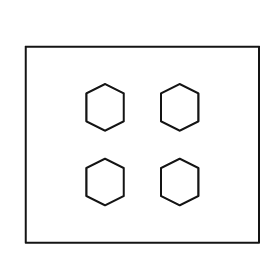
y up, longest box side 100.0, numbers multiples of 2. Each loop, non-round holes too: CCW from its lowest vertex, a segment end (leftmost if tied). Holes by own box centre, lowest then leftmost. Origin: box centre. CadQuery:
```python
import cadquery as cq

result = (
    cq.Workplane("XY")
    .moveTo(-50.0, -42.0)
    .lineTo(50.0, -42.0)
    .lineTo(50.0, 42.0)
    .lineTo(-50.0, 42.0)
    .close()
    .moveTo(-16.0, -26.0)
    .lineTo(-8.0, -22.0)
    .lineTo(-8.0, -10.0)
    .lineTo(-16.0, -6.0)
    .lineTo(-24.0, -10.0)
    .lineTo(-24.0, -22.0)
    .close()
    .moveTo(16.0, -26.0)
    .lineTo(24.0, -22.0)
    .lineTo(24.0, -10.0)
    .lineTo(16.0, -6.0)
    .lineTo(8.0, -10.0)
    .lineTo(8.0, -22.0)
    .close()
    .moveTo(-16.0, 6.0)
    .lineTo(-8.0, 10.0)
    .lineTo(-8.0, 22.0)
    .lineTo(-16.0, 26.0)
    .lineTo(-24.0, 22.0)
    .lineTo(-24.0, 10.0)
    .close()
    .moveTo(16.0, 6.0)
    .lineTo(24.0, 10.0)
    .lineTo(24.0, 22.0)
    .lineTo(16.0, 26.0)
    .lineTo(8.0, 22.0)
    .lineTo(8.0, 10.0)
    .close()
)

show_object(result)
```